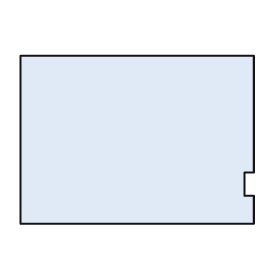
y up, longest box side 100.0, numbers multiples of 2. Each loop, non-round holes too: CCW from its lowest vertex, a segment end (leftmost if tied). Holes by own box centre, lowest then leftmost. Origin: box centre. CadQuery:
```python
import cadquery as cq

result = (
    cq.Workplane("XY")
    .moveTo(-50.0, -36.0)
    .lineTo(50.0, -36.0)
    .lineTo(50.0, -24.0)
    .lineTo(46.0, -24.0)
    .lineTo(46.0, -14.0)
    .lineTo(50.0, -14.0)
    .lineTo(50.0, 36.0)
    .lineTo(-50.0, 36.0)
    .close()
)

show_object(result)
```